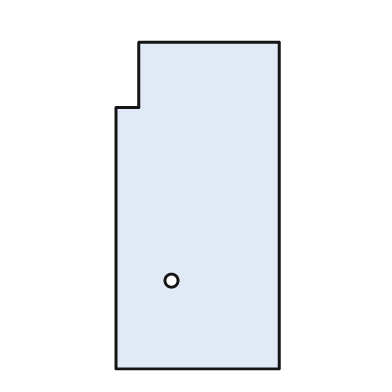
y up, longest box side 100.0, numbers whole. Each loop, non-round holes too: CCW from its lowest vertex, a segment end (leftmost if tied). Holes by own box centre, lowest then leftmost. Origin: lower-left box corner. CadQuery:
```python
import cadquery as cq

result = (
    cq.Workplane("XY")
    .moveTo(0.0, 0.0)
    .lineTo(50.0, 0.0)
    .lineTo(50.0, 100.0)
    .lineTo(7.0, 100.0)
    .lineTo(7.0, 80.0)
    .lineTo(0.0, 80.0)
    .close()
    .moveTo(17.0, 27.0)
    .circle(2.0)
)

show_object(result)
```